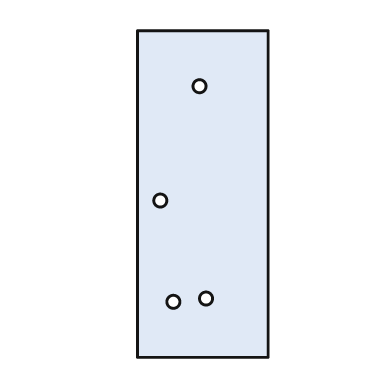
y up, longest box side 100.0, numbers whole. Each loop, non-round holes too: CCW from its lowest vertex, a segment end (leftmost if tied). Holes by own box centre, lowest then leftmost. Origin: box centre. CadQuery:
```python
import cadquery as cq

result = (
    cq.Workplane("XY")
    .moveTo(-20.0, -50.0)
    .lineTo(20.0, -50.0)
    .lineTo(20.0, 50.0)
    .lineTo(-20.0, 50.0)
    .close()
    .moveTo(-9.0, -33.0)
    .circle(2.0)
    .moveTo(1.0, -32.0)
    .circle(2.0)
    .moveTo(-13.0, -2.0)
    .circle(2.0)
    .moveTo(-1.0, 33.0)
    .circle(2.0)
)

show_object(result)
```